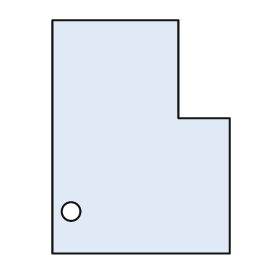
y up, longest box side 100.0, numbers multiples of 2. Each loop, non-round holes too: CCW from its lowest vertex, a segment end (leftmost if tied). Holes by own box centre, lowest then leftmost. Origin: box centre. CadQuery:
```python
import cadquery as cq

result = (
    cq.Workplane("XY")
    .moveTo(-38.0, -50.0)
    .lineTo(38.0, -50.0)
    .lineTo(38.0, 8.0)
    .lineTo(16.0, 8.0)
    .lineTo(16.0, 50.0)
    .lineTo(-38.0, 50.0)
    .close()
    .moveTo(-30.0, -32.0)
    .circle(4.0)
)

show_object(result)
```